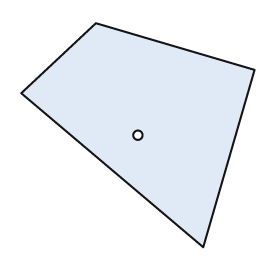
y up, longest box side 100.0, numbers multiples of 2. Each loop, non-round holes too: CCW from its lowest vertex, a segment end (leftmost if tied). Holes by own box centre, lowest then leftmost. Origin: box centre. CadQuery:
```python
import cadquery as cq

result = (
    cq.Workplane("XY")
    .moveTo(28.0, -48.0)
    .lineTo(50.0, 28.0)
    .lineTo(-18.0, 48.0)
    .lineTo(-50.0, 18.0)
    .close()
    .moveTo(0.0, 0.0)
    .circle(2.0)
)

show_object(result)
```